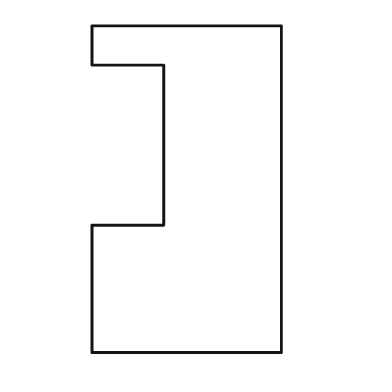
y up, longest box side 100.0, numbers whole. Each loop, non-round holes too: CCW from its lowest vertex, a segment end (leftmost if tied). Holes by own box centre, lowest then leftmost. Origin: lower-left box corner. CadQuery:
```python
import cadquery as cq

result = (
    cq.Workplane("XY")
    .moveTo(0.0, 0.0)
    .lineTo(58.0, 0.0)
    .lineTo(58.0, 100.0)
    .lineTo(0.0, 100.0)
    .lineTo(0.0, 88.0)
    .lineTo(22.0, 88.0)
    .lineTo(22.0, 39.0)
    .lineTo(0.0, 39.0)
    .close()
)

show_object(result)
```